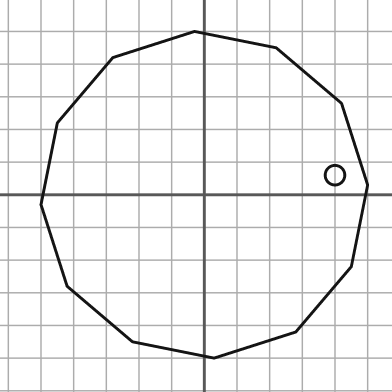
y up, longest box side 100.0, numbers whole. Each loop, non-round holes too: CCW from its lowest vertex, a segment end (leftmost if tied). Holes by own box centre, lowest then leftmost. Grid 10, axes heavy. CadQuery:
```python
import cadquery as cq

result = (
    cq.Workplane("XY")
    .moveTo(3.0, -50.0)
    .lineTo(28.0, -42.0)
    .lineTo(45.0, -22.0)
    .lineTo(50.0, 3.0)
    .lineTo(42.0, 28.0)
    .lineTo(22.0, 45.0)
    .lineTo(-3.0, 50.0)
    .lineTo(-28.0, 42.0)
    .lineTo(-45.0, 22.0)
    .lineTo(-50.0, -3.0)
    .lineTo(-42.0, -28.0)
    .lineTo(-22.0, -45.0)
    .close()
    .moveTo(40.0, 6.0)
    .circle(3.0)
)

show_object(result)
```